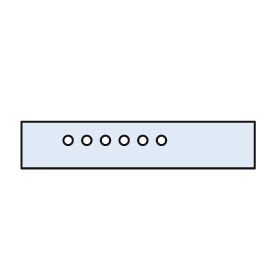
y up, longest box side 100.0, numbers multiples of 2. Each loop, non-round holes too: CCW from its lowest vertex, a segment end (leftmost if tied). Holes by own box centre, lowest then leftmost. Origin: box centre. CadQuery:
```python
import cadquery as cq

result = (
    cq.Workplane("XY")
    .moveTo(-50.0, -10.0)
    .lineTo(50.0, -10.0)
    .lineTo(50.0, 10.0)
    .lineTo(-50.0, 10.0)
    .close()
    .moveTo(-30.0, 2.0)
    .circle(2.0)
    .moveTo(-22.0, 2.0)
    .circle(2.0)
    .moveTo(-14.0, 2.0)
    .circle(2.0)
    .moveTo(-6.0, 2.0)
    .circle(2.0)
    .moveTo(2.0, 2.0)
    .circle(2.0)
    .moveTo(10.0, 2.0)
    .circle(2.0)
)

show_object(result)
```